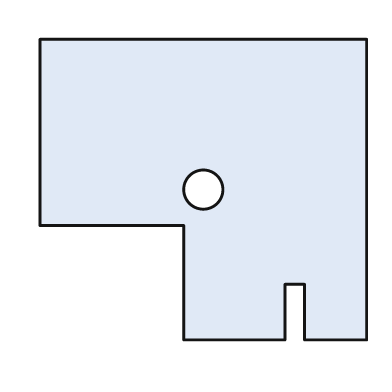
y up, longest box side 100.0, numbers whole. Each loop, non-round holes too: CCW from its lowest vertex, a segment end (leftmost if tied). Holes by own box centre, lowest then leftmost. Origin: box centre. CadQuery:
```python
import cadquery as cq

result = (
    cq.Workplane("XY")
    .moveTo(-6.0, -46.0)
    .lineTo(25.0, -46.0)
    .lineTo(25.0, -29.0)
    .lineTo(31.0, -29.0)
    .lineTo(31.0, -46.0)
    .lineTo(50.0, -46.0)
    .lineTo(50.0, 46.0)
    .lineTo(-50.0, 46.0)
    .lineTo(-50.0, -11.0)
    .lineTo(-6.0, -11.0)
    .close()
    .moveTo(0.0, 0.0)
    .circle(6.0)
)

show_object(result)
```